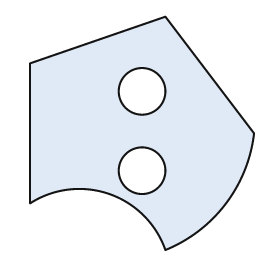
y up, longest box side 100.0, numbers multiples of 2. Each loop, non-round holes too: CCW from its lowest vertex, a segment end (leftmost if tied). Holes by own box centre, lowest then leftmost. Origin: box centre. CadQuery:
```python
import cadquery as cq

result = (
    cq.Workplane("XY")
    .moveTo(10.0, -50.0)
    .threePointArc((36.0, -30.0), (48.0, 0.0))
    .lineTo(10.0, 50.0)
    .lineTo(-48.0, 30.0)
    .lineTo(-48.0, -30.0)
    .threePointArc((-14.0, -26.0), (10.0, -50.0))
    .close()
    .moveTo(0.0, -16.0)
    .circle(10.0)
    .moveTo(0.0, 18.0)
    .circle(10.0)
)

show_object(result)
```